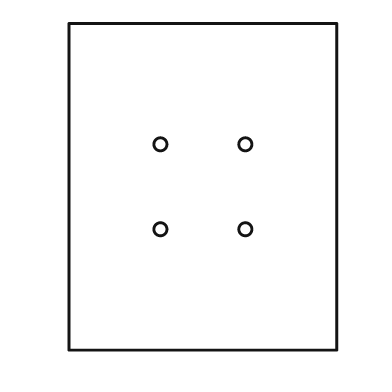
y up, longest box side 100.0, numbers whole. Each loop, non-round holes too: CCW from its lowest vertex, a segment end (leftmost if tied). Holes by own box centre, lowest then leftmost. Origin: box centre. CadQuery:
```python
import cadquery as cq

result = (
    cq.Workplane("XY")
    .moveTo(-41.0, -50.0)
    .lineTo(41.0, -50.0)
    .lineTo(41.0, 50.0)
    .lineTo(-41.0, 50.0)
    .close()
    .moveTo(-13.0, -13.0)
    .circle(2.0)
    .moveTo(13.0, -13.0)
    .circle(2.0)
    .moveTo(-13.0, 13.0)
    .circle(2.0)
    .moveTo(13.0, 13.0)
    .circle(2.0)
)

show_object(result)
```